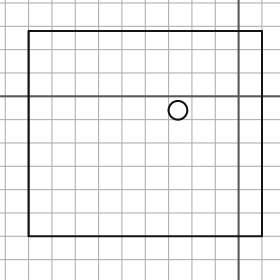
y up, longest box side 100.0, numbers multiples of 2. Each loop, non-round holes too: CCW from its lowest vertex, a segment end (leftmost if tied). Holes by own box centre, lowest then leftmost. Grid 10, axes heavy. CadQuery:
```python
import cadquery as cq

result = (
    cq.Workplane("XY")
    .moveTo(-90.0, -60.0)
    .lineTo(10.0, -60.0)
    .lineTo(10.0, 28.0)
    .lineTo(-90.0, 28.0)
    .close()
    .moveTo(-26.0, -6.0)
    .circle(4.0)
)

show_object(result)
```